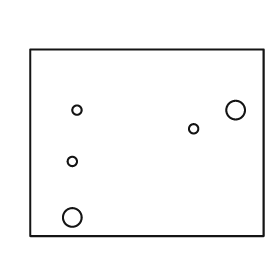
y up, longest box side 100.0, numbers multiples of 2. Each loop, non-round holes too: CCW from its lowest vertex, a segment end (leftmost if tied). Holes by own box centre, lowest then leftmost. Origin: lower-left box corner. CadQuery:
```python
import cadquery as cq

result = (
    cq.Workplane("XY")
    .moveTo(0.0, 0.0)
    .lineTo(100.0, 0.0)
    .lineTo(100.0, 80.0)
    .lineTo(0.0, 80.0)
    .close()
    .moveTo(18.0, 8.0)
    .circle(4.0)
    .moveTo(18.0, 32.0)
    .circle(2.0)
    .moveTo(70.0, 46.0)
    .circle(2.0)
    .moveTo(20.0, 54.0)
    .circle(2.0)
    .moveTo(88.0, 54.0)
    .circle(4.0)
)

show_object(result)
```